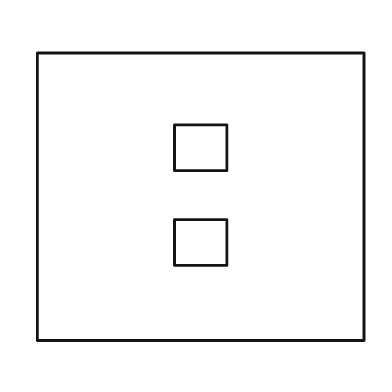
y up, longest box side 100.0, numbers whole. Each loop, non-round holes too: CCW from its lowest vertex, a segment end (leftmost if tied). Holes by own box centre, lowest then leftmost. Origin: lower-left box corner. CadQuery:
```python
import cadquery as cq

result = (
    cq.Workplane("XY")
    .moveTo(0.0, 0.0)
    .lineTo(100.0, 0.0)
    .lineTo(100.0, 88.0)
    .lineTo(0.0, 88.0)
    .close()
    .moveTo(42.0, 23.0)
    .lineTo(58.0, 23.0)
    .lineTo(58.0, 37.0)
    .lineTo(42.0, 37.0)
    .close()
    .moveTo(42.0, 52.0)
    .lineTo(58.0, 52.0)
    .lineTo(58.0, 66.0)
    .lineTo(42.0, 66.0)
    .close()
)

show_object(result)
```